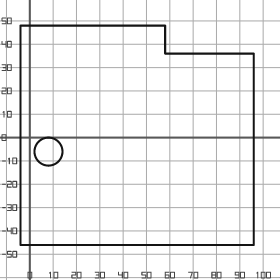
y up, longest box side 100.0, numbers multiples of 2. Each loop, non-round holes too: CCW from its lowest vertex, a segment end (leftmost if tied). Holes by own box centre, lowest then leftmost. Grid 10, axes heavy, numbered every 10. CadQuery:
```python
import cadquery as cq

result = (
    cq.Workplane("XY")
    .moveTo(-4.0, -46.0)
    .lineTo(96.0, -46.0)
    .lineTo(96.0, 36.0)
    .lineTo(58.0, 36.0)
    .lineTo(58.0, 48.0)
    .lineTo(-4.0, 48.0)
    .close()
    .moveTo(8.0, -6.0)
    .circle(6.0)
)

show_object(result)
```